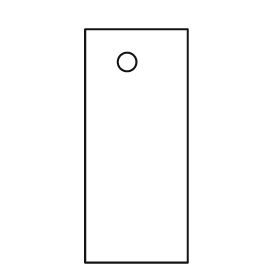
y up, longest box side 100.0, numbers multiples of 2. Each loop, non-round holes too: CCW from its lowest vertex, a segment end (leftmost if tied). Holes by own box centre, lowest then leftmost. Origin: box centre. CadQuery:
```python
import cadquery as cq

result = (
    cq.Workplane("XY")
    .moveTo(-22.0, -50.0)
    .lineTo(22.0, -50.0)
    .lineTo(22.0, 50.0)
    .lineTo(-22.0, 50.0)
    .close()
    .moveTo(-4.0, 36.0)
    .circle(4.0)
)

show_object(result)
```